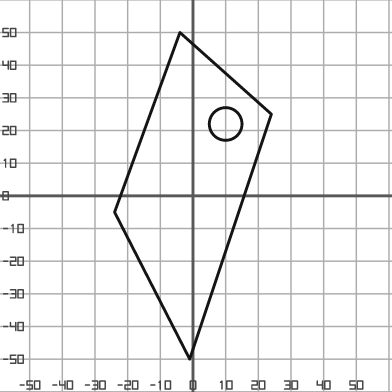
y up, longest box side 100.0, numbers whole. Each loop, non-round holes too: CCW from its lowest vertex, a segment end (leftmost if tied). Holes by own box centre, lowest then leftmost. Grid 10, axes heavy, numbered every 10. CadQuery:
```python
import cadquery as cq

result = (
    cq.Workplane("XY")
    .moveTo(-1.0, -50.0)
    .lineTo(24.0, 25.0)
    .lineTo(-4.0, 50.0)
    .lineTo(-24.0, -5.0)
    .close()
    .moveTo(10.0, 22.0)
    .circle(5.0)
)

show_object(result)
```